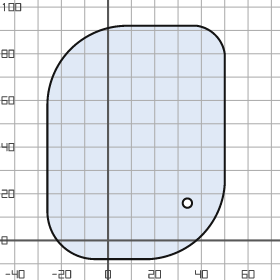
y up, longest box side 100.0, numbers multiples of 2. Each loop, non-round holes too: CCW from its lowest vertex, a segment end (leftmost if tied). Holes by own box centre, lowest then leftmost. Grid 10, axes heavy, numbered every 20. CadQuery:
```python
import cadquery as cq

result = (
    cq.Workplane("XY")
    .moveTo(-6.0, -8.0)
    .lineTo(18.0, -8.0)
    .threePointArc((40.0, 2.0), (50.0, 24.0))
    .lineTo(50.0, 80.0)
    .threePointArc((46.0, 88.0), (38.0, 92.0))
    .lineTo(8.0, 92.0)
    .threePointArc((-16.0, 82.0), (-26.0, 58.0))
    .lineTo(-26.0, 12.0)
    .threePointArc((-20.0, -2.0), (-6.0, -8.0))
    .close()
    .moveTo(34.0, 16.0)
    .circle(2.0)
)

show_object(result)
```